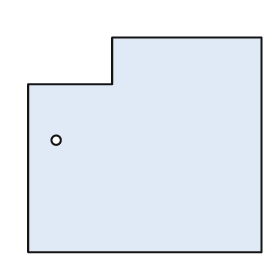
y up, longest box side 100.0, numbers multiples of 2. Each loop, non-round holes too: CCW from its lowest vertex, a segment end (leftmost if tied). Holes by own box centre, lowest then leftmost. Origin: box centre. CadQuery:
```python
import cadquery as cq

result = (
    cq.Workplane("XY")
    .moveTo(-50.0, -46.0)
    .lineTo(50.0, -46.0)
    .lineTo(50.0, 46.0)
    .lineTo(-14.0, 46.0)
    .lineTo(-14.0, 26.0)
    .lineTo(-50.0, 26.0)
    .close()
    .moveTo(-38.0, 2.0)
    .circle(2.0)
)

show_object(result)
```